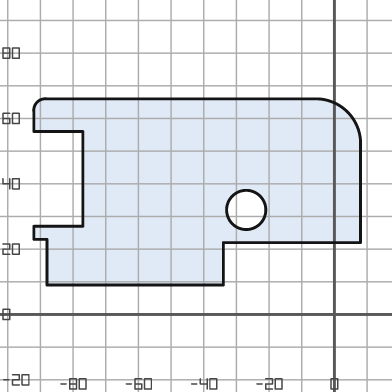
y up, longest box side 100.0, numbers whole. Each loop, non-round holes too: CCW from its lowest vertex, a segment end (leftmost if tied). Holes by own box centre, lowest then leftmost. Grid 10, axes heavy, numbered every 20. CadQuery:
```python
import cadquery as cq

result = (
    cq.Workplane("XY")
    .moveTo(-88.0, 9.0)
    .lineTo(-34.0, 9.0)
    .lineTo(-34.0, 22.0)
    .lineTo(8.0, 22.0)
    .lineTo(8.0, 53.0)
    .threePointArc((4.0, 62.0), (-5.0, 66.0))
    .lineTo(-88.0, 66.0)
    .threePointArc((-91.0, 65.0), (-92.0, 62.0))
    .lineTo(-92.0, 56.0)
    .lineTo(-77.0, 56.0)
    .lineTo(-77.0, 27.0)
    .lineTo(-92.0, 27.0)
    .lineTo(-92.0, 23.0)
    .lineTo(-88.0, 23.0)
    .close()
    .moveTo(-27.0, 32.0)
    .circle(6.0)
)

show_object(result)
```